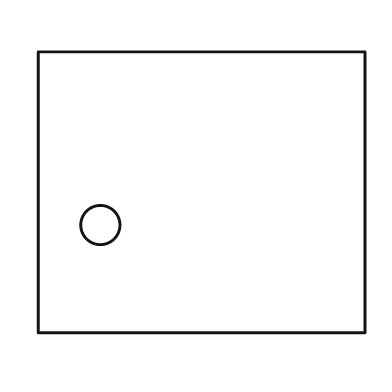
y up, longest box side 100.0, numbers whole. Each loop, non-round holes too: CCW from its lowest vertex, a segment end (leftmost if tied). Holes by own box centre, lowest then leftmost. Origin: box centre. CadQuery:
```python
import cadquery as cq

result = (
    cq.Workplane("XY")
    .moveTo(-50.0, -43.0)
    .lineTo(50.0, -43.0)
    .lineTo(50.0, 43.0)
    .lineTo(-50.0, 43.0)
    .close()
    .moveTo(-31.0, -10.0)
    .circle(6.0)
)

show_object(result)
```